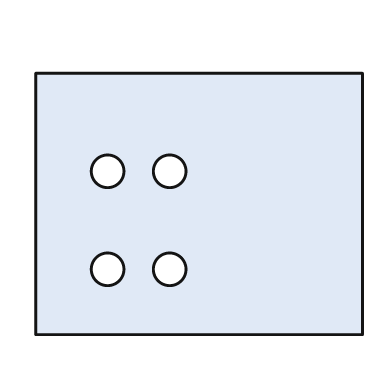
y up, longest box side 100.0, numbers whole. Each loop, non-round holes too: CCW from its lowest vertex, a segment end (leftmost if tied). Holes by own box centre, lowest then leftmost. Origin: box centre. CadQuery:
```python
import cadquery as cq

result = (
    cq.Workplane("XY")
    .moveTo(-50.0, -40.0)
    .lineTo(50.0, -40.0)
    .lineTo(50.0, 40.0)
    .lineTo(-50.0, 40.0)
    .close()
    .moveTo(-28.0, -20.0)
    .circle(5.0)
    .moveTo(-9.0, -20.0)
    .circle(5.0)
    .moveTo(-28.0, 10.0)
    .circle(5.0)
    .moveTo(-9.0, 10.0)
    .circle(5.0)
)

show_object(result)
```